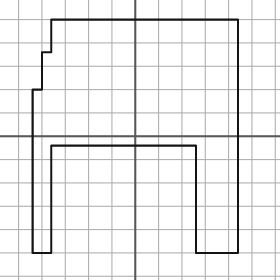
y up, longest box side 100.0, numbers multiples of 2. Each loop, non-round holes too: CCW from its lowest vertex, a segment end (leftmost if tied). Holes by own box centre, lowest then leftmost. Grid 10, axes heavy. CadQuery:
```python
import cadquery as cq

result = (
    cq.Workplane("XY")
    .moveTo(-44.0, -50.0)
    .lineTo(-36.0, -50.0)
    .lineTo(-36.0, -4.0)
    .lineTo(26.0, -4.0)
    .lineTo(26.0, -50.0)
    .lineTo(44.0, -50.0)
    .lineTo(44.0, 50.0)
    .lineTo(-36.0, 50.0)
    .lineTo(-36.0, 36.0)
    .lineTo(-40.0, 36.0)
    .lineTo(-40.0, 20.0)
    .lineTo(-44.0, 20.0)
    .close()
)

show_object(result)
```